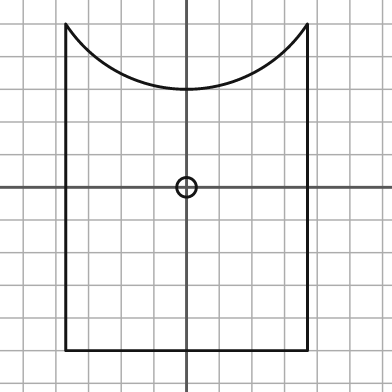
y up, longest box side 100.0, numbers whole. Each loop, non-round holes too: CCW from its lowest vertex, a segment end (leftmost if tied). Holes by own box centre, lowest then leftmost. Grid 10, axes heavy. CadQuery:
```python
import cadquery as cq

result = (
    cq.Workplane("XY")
    .moveTo(-37.0, -50.0)
    .lineTo(37.0, -50.0)
    .lineTo(37.0, 50.0)
    .threePointArc((0.0, 30.0), (-37.0, 50.0))
    .close()
    .moveTo(0.0, 0.0)
    .circle(3.0)
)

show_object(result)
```